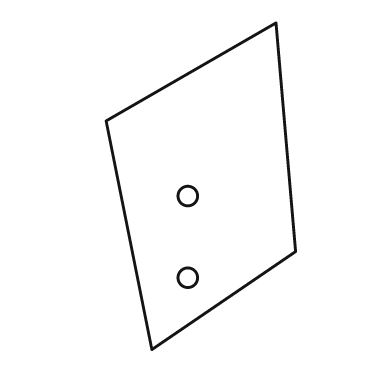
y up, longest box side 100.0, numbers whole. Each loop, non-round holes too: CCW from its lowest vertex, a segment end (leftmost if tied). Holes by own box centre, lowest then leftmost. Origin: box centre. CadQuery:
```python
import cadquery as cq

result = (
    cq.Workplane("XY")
    .moveTo(-15.0, -50.0)
    .lineTo(29.0, -20.0)
    .lineTo(23.0, 50.0)
    .lineTo(-29.0, 20.0)
    .close()
    .moveTo(-4.0, -28.0)
    .circle(3.0)
    .moveTo(-4.0, -3.0)
    .circle(3.0)
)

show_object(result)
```